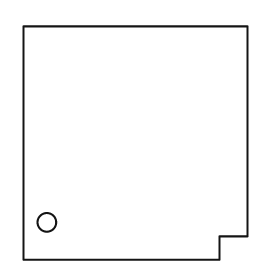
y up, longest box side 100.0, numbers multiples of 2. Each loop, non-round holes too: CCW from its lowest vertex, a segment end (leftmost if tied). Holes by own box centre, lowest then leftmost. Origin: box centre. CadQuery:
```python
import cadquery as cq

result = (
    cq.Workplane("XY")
    .moveTo(-48.0, -50.0)
    .lineTo(36.0, -50.0)
    .lineTo(36.0, -40.0)
    .lineTo(48.0, -40.0)
    .lineTo(48.0, 50.0)
    .lineTo(-48.0, 50.0)
    .close()
    .moveTo(-38.0, -34.0)
    .circle(4.0)
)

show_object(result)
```